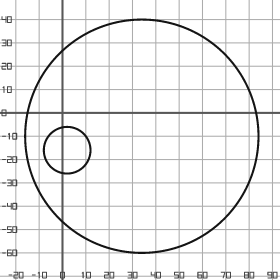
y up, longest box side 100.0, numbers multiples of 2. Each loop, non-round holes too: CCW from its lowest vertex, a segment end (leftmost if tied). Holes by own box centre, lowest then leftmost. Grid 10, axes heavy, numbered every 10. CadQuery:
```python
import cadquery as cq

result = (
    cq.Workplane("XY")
    .moveTo(34.0, -10.0)
    .circle(50.0)
    .moveTo(2.0, -16.0)
    .circle(10.0)
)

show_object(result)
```